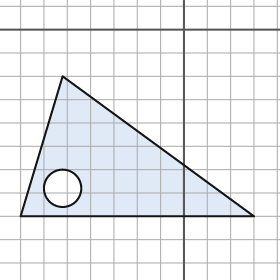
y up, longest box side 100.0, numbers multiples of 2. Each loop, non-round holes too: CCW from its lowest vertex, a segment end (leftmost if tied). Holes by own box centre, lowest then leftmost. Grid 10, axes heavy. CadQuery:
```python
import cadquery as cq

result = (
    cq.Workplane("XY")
    .moveTo(-70.0, -80.0)
    .lineTo(30.0, -80.0)
    .lineTo(-52.0, -20.0)
    .close()
    .moveTo(-52.0, -68.0)
    .circle(8.0)
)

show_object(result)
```